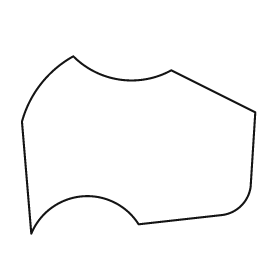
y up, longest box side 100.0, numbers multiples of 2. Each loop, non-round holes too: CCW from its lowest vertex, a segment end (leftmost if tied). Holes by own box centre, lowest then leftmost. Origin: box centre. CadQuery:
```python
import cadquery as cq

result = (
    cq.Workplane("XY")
    .moveTo(-46.0, -38.0)
    .threePointArc((-24.0, -22.0), (0.0, -34.0))
    .lineTo(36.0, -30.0)
    .threePointArc((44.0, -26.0), (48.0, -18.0))
    .lineTo(50.0, 14.0)
    .lineTo(14.0, 32.0)
    .threePointArc((-8.0, 28.0), (-28.0, 38.0))
    .threePointArc((-42.0, 26.0), (-50.0, 10.0))
    .close()
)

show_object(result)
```